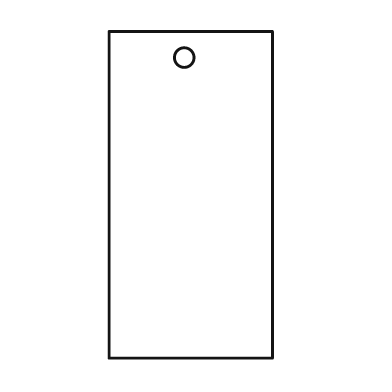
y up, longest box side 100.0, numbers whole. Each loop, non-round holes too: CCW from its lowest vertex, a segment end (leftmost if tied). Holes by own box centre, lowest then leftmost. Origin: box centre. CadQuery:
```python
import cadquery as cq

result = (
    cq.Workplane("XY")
    .moveTo(-25.0, -50.0)
    .lineTo(25.0, -50.0)
    .lineTo(25.0, 50.0)
    .lineTo(-25.0, 50.0)
    .close()
    .moveTo(-2.0, 42.0)
    .circle(3.0)
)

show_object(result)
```